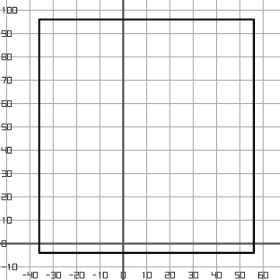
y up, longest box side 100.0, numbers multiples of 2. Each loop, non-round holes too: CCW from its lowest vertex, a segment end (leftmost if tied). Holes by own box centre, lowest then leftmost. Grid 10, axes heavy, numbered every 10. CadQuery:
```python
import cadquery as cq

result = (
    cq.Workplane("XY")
    .moveTo(-36.0, -4.0)
    .lineTo(56.0, -4.0)
    .lineTo(56.0, 96.0)
    .lineTo(-36.0, 96.0)
    .close()
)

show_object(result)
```